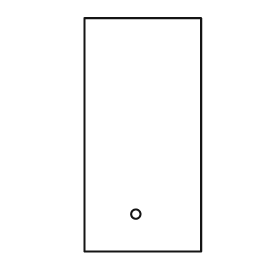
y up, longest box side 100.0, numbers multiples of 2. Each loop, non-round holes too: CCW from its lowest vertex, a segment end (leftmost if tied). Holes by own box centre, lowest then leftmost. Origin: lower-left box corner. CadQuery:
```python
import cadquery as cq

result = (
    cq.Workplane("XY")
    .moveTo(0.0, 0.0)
    .lineTo(50.0, 0.0)
    .lineTo(50.0, 100.0)
    .lineTo(0.0, 100.0)
    .close()
    .moveTo(22.0, 16.0)
    .circle(2.0)
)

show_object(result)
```